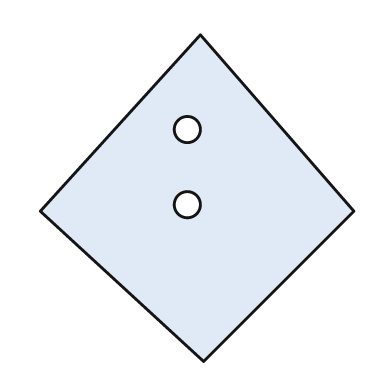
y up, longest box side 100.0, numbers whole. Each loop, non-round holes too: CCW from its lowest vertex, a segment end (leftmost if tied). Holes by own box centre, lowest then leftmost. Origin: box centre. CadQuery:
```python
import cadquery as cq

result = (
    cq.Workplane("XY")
    .moveTo(2.0, -50.0)
    .lineTo(48.0, -4.0)
    .lineTo(1.0, 50.0)
    .lineTo(-48.0, -4.0)
    .close()
    .moveTo(-3.0, -2.0)
    .circle(4.0)
    .moveTo(-3.0, 21.0)
    .circle(4.0)
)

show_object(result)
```